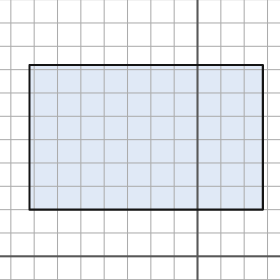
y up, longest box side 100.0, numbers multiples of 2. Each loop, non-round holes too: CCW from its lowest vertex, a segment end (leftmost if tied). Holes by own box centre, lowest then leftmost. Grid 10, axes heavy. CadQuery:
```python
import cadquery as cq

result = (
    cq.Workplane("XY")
    .moveTo(-72.0, 20.0)
    .lineTo(28.0, 20.0)
    .lineTo(28.0, 82.0)
    .lineTo(-72.0, 82.0)
    .close()
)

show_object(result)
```